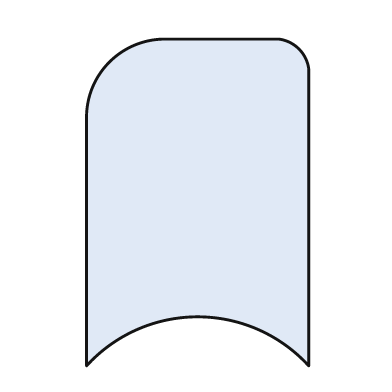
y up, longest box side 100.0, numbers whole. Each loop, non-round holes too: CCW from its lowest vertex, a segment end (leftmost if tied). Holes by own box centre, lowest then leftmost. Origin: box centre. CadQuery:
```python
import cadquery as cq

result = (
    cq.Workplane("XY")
    .moveTo(-34.0, -50.0)
    .threePointArc((0.0, -35.0), (34.0, -50.0))
    .lineTo(34.0, 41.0)
    .threePointArc((31.0, 47.0), (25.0, 50.0))
    .lineTo(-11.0, 50.0)
    .threePointArc((-27.0, 43.0), (-34.0, 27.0))
    .close()
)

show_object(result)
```